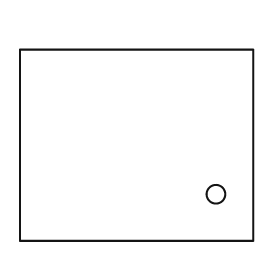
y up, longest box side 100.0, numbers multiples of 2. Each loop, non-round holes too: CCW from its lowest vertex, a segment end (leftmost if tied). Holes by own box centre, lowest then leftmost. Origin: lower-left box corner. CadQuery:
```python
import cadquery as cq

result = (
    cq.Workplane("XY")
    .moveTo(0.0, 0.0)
    .lineTo(100.0, 0.0)
    .lineTo(100.0, 82.0)
    .lineTo(0.0, 82.0)
    .close()
    .moveTo(84.0, 20.0)
    .circle(4.0)
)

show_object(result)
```